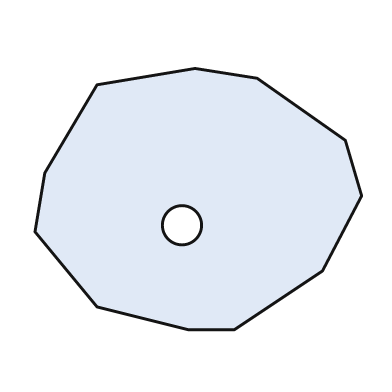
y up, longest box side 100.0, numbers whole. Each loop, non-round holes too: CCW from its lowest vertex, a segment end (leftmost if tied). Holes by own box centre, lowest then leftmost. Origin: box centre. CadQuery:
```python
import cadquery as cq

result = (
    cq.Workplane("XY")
    .moveTo(-3.0, -40.0)
    .lineTo(11.0, -40.0)
    .lineTo(38.0, -22.0)
    .lineTo(50.0, 1.0)
    .lineTo(45.0, 18.0)
    .lineTo(18.0, 37.0)
    .lineTo(-1.0, 40.0)
    .lineTo(-31.0, 35.0)
    .lineTo(-47.0, 8.0)
    .lineTo(-50.0, -10.0)
    .lineTo(-31.0, -33.0)
    .close()
    .moveTo(-5.0, -8.0)
    .circle(6.0)
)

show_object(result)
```